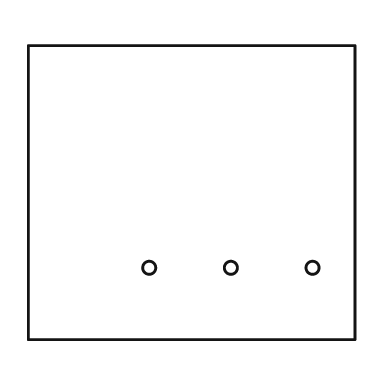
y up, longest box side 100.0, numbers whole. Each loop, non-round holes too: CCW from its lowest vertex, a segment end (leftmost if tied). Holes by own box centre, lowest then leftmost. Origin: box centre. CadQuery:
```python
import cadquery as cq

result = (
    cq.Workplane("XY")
    .moveTo(-50.0, -45.0)
    .lineTo(50.0, -45.0)
    .lineTo(50.0, 45.0)
    .lineTo(-50.0, 45.0)
    .close()
    .moveTo(-13.0, -23.0)
    .circle(2.0)
    .moveTo(12.0, -23.0)
    .circle(2.0)
    .moveTo(37.0, -23.0)
    .circle(2.0)
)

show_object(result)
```